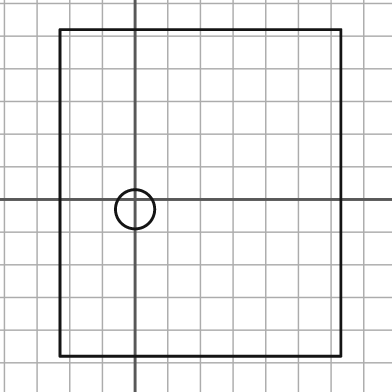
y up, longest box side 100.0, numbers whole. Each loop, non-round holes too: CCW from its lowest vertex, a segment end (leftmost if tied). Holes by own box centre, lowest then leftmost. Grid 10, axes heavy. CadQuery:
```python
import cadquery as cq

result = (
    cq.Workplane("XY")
    .moveTo(-23.0, -48.0)
    .lineTo(63.0, -48.0)
    .lineTo(63.0, 52.0)
    .lineTo(-23.0, 52.0)
    .close()
    .moveTo(0.0, -3.0)
    .circle(6.0)
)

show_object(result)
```